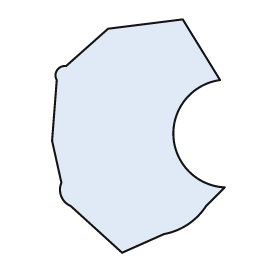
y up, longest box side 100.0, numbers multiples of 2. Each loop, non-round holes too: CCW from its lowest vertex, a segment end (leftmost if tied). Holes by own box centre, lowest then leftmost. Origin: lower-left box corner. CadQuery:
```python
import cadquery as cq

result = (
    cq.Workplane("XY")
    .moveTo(30.0, 0.0)
    .lineTo(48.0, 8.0)
    .threePointArc((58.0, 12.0), (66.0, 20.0))
    .lineTo(74.0, 28.0)
    .threePointArc((52.0, 50.0), (72.0, 74.0))
    .lineTo(56.0, 100.0)
    .lineTo(24.0, 96.0)
    .lineTo(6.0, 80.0)
    .threePointArc((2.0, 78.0), (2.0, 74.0))
    .lineTo(0.0, 48.0)
    .lineTo(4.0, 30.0)
    .threePointArc((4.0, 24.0), (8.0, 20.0))
    .close()
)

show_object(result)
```